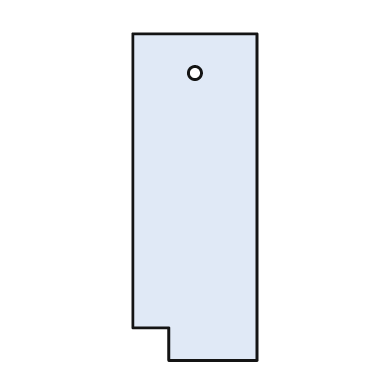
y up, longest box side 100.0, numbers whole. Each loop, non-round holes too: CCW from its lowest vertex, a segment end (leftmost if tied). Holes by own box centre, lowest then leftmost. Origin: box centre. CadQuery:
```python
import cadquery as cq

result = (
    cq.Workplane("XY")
    .moveTo(-8.0, -50.0)
    .lineTo(19.0, -50.0)
    .lineTo(19.0, 50.0)
    .lineTo(-19.0, 50.0)
    .lineTo(-19.0, -40.0)
    .lineTo(-8.0, -40.0)
    .close()
    .moveTo(0.0, 38.0)
    .circle(2.0)
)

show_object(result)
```